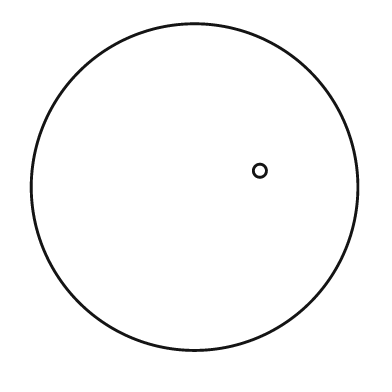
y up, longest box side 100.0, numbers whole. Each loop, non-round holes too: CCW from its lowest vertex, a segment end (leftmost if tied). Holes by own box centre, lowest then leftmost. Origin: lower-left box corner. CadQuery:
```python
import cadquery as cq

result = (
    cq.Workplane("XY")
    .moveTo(50.0, 50.0)
    .circle(50.0)
    .moveTo(70.0, 55.0)
    .circle(2.0)
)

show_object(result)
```